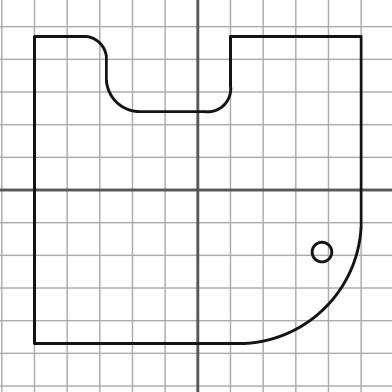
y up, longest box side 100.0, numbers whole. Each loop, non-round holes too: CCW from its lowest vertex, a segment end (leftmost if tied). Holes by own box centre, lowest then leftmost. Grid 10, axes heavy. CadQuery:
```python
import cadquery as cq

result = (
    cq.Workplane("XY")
    .moveTo(-50.0, -47.0)
    .lineTo(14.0, -47.0)
    .threePointArc((39.0, -36.0), (50.0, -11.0))
    .lineTo(50.0, 47.0)
    .lineTo(10.0, 47.0)
    .lineTo(10.0, 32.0)
    .threePointArc((8.0, 26.0), (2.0, 24.0))
    .lineTo(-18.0, 24.0)
    .threePointArc((-25.0, 27.0), (-28.0, 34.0))
    .lineTo(-28.0, 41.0)
    .threePointArc((-30.0, 45.0), (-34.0, 47.0))
    .lineTo(-50.0, 47.0)
    .close()
    .moveTo(38.0, -19.0)
    .circle(3.0)
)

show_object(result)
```